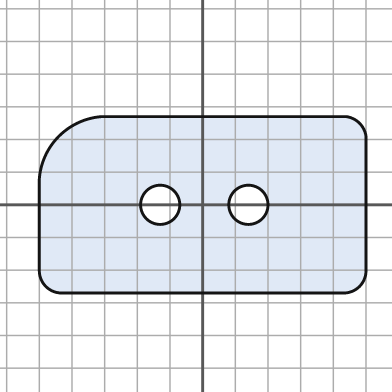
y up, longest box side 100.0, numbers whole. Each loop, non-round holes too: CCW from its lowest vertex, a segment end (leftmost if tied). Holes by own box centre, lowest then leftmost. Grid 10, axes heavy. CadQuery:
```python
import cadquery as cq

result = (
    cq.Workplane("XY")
    .moveTo(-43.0, -27.0)
    .lineTo(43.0, -27.0)
    .threePointArc((48.0, -25.0), (50.0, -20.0))
    .lineTo(50.0, 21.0)
    .threePointArc((48.0, 25.0), (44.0, 27.0))
    .lineTo(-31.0, 27.0)
    .threePointArc((-44.0, 21.0), (-50.0, 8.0))
    .lineTo(-50.0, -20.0)
    .threePointArc((-48.0, -25.0), (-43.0, -27.0))
    .close()
    .moveTo(-13.0, 0.0)
    .circle(6.0)
    .moveTo(14.0, 0.0)
    .circle(6.0)
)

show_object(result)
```